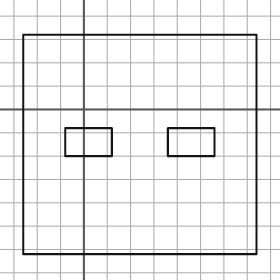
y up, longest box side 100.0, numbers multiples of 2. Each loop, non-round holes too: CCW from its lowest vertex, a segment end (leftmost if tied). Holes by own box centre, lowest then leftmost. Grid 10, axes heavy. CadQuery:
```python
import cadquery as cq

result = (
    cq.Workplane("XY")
    .moveTo(-26.0, -62.0)
    .lineTo(74.0, -62.0)
    .lineTo(74.0, 32.0)
    .lineTo(-26.0, 32.0)
    .close()
    .moveTo(-8.0, -20.0)
    .lineTo(12.0, -20.0)
    .lineTo(12.0, -8.0)
    .lineTo(-8.0, -8.0)
    .close()
    .moveTo(36.0, -20.0)
    .lineTo(56.0, -20.0)
    .lineTo(56.0, -8.0)
    .lineTo(36.0, -8.0)
    .close()
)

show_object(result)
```